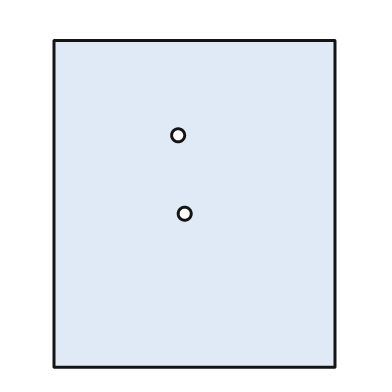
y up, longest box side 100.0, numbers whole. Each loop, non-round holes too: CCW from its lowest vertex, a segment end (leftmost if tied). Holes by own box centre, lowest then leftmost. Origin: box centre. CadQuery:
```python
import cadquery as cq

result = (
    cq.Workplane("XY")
    .moveTo(-43.0, -50.0)
    .lineTo(43.0, -50.0)
    .lineTo(43.0, 50.0)
    .lineTo(-43.0, 50.0)
    .close()
    .moveTo(-3.0, -3.0)
    .circle(2.0)
    .moveTo(-5.0, 21.0)
    .circle(2.0)
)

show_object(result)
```